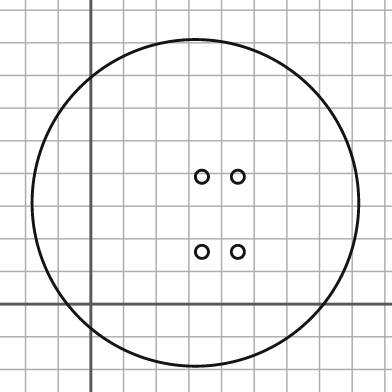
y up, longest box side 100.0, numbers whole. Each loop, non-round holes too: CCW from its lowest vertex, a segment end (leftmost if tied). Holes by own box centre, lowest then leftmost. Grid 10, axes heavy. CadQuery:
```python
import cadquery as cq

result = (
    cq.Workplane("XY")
    .moveTo(32.0, 31.0)
    .circle(50.0)
    .moveTo(34.0, 16.0)
    .circle(2.0)
    .moveTo(45.0, 16.0)
    .circle(2.0)
    .moveTo(34.0, 39.0)
    .circle(2.0)
    .moveTo(45.0, 39.0)
    .circle(2.0)
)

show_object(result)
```